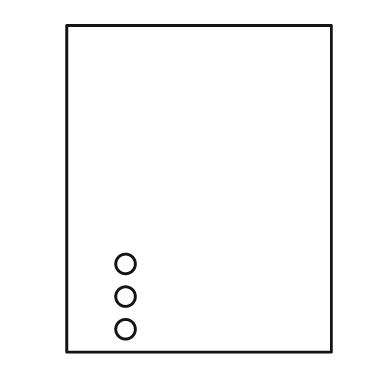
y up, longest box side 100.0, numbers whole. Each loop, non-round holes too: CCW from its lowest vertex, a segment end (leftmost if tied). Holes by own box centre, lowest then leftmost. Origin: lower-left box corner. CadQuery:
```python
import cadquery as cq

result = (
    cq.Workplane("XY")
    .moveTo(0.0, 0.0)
    .lineTo(81.0, 0.0)
    .lineTo(81.0, 100.0)
    .lineTo(0.0, 100.0)
    .close()
    .moveTo(18.0, 7.0)
    .circle(3.0)
    .moveTo(18.0, 17.0)
    .circle(3.0)
    .moveTo(18.0, 27.0)
    .circle(3.0)
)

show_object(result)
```